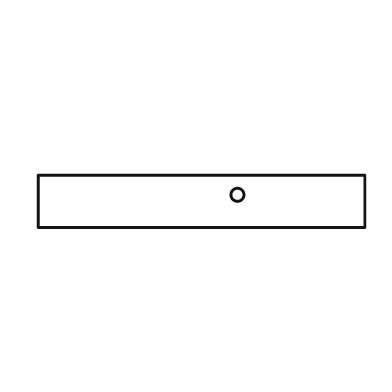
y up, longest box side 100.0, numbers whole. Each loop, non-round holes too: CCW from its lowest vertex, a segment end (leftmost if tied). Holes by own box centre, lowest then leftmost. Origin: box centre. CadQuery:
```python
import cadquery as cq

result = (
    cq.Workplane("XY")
    .moveTo(-50.0, -8.0)
    .lineTo(50.0, -8.0)
    .lineTo(50.0, 8.0)
    .lineTo(-50.0, 8.0)
    .close()
    .moveTo(11.0, 2.0)
    .circle(2.0)
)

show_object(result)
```